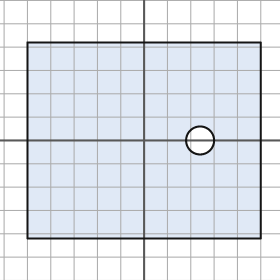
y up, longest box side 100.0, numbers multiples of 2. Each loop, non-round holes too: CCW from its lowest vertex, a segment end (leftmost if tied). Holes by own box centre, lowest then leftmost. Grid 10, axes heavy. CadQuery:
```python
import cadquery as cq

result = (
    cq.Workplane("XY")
    .moveTo(-50.0, -42.0)
    .lineTo(50.0, -42.0)
    .lineTo(50.0, 42.0)
    .lineTo(-50.0, 42.0)
    .close()
    .moveTo(24.0, 0.0)
    .circle(6.0)
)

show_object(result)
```